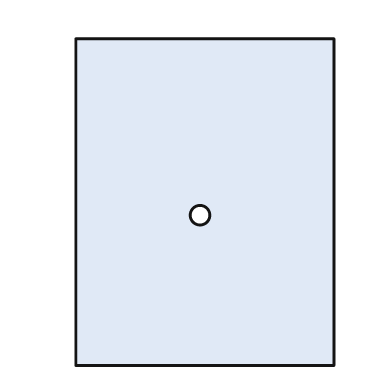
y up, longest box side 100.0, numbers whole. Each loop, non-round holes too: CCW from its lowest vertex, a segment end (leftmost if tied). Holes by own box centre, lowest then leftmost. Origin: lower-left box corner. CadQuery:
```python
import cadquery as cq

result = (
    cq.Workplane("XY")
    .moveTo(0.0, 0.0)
    .lineTo(79.0, 0.0)
    .lineTo(79.0, 100.0)
    .lineTo(0.0, 100.0)
    .close()
    .moveTo(38.0, 46.0)
    .circle(3.0)
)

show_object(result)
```